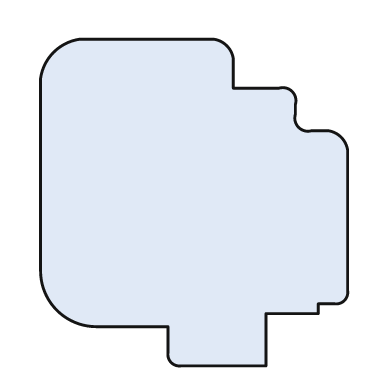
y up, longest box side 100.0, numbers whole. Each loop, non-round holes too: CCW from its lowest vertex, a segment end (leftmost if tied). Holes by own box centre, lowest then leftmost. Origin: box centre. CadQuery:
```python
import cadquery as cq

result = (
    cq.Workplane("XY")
    .moveTo(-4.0, -50.0)
    .lineTo(22.0, -50.0)
    .lineTo(22.0, -34.0)
    .lineTo(38.0, -34.0)
    .lineTo(38.0, -31.0)
    .lineTo(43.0, -31.0)
    .threePointArc((46.0, -30.0), (47.0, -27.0))
    .lineTo(47.0, 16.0)
    .threePointArc((45.0, 20.0), (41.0, 22.0))
    .lineTo(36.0, 22.0)
    .threePointArc((32.0, 23.0), (31.0, 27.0))
    .lineTo(31.0, 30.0)
    .threePointArc((30.0, 34.0), (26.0, 35.0))
    .lineTo(12.0, 35.0)
    .lineTo(12.0, 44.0)
    .threePointArc((10.0, 48.0), (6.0, 50.0))
    .lineTo(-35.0, 50.0)
    .threePointArc((-43.0, 46.0), (-47.0, 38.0))
    .lineTo(-47.0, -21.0)
    .threePointArc((-42.0, -33.0), (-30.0, -38.0))
    .lineTo(-8.0, -38.0)
    .lineTo(-8.0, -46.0)
    .threePointArc((-7.0, -49.0), (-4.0, -50.0))
    .close()
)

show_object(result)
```